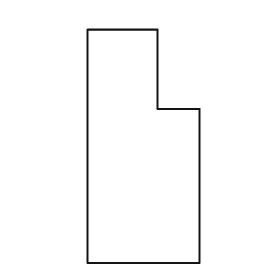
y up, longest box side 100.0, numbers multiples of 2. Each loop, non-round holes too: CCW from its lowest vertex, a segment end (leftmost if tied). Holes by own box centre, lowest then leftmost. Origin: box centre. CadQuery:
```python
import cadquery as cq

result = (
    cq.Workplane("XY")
    .moveTo(-24.0, -50.0)
    .lineTo(24.0, -50.0)
    .lineTo(24.0, 16.0)
    .lineTo(6.0, 16.0)
    .lineTo(6.0, 50.0)
    .lineTo(-24.0, 50.0)
    .close()
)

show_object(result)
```